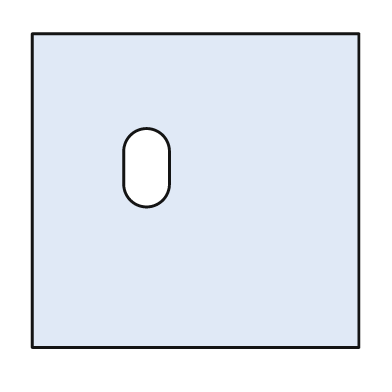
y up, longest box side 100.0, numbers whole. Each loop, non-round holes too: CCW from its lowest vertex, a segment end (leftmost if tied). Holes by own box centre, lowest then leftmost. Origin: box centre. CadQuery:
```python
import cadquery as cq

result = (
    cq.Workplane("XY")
    .moveTo(-50.0, -48.0)
    .lineTo(50.0, -48.0)
    .lineTo(50.0, 48.0)
    .lineTo(-50.0, 48.0)
    .close()
    .moveTo(-22.0, 2.0)
    .threePointArc((-15.0, -5.0), (-8.0, 2.0))
    .lineTo(-8.0, 12.0)
    .threePointArc((-15.0, 19.0), (-22.0, 12.0))
    .close()
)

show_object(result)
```